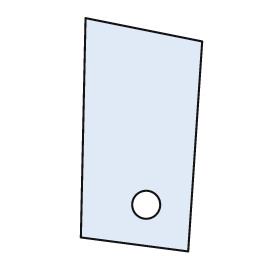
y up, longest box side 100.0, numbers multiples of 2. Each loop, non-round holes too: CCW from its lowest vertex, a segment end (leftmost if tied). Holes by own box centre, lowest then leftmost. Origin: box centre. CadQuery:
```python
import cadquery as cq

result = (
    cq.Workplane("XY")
    .moveTo(20.0, -50.0)
    .lineTo(26.0, 40.0)
    .lineTo(-24.0, 50.0)
    .lineTo(-26.0, -44.0)
    .close()
    .moveTo(2.0, -30.0)
    .circle(6.0)
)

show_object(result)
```